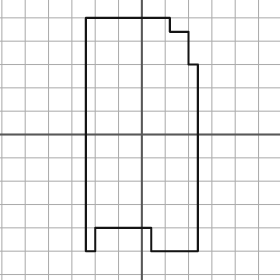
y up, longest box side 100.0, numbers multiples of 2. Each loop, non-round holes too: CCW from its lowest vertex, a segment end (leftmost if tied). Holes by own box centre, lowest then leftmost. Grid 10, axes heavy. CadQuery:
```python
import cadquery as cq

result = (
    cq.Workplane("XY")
    .moveTo(-24.0, -50.0)
    .lineTo(-20.0, -50.0)
    .lineTo(-20.0, -40.0)
    .lineTo(4.0, -40.0)
    .lineTo(4.0, -50.0)
    .lineTo(24.0, -50.0)
    .lineTo(24.0, 30.0)
    .lineTo(20.0, 30.0)
    .lineTo(20.0, 44.0)
    .lineTo(12.0, 44.0)
    .lineTo(12.0, 50.0)
    .lineTo(-24.0, 50.0)
    .close()
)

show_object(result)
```